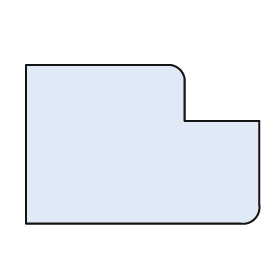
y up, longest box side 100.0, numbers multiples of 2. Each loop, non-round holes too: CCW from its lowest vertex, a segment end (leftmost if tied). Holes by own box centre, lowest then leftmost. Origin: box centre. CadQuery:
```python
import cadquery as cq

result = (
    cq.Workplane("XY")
    .moveTo(-50.0, -34.0)
    .lineTo(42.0, -34.0)
    .threePointArc((48.0, -32.0), (50.0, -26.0))
    .lineTo(50.0, 10.0)
    .lineTo(18.0, 10.0)
    .lineTo(18.0, 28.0)
    .threePointArc((16.0, 32.0), (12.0, 34.0))
    .lineTo(-50.0, 34.0)
    .close()
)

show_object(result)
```